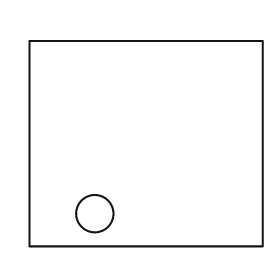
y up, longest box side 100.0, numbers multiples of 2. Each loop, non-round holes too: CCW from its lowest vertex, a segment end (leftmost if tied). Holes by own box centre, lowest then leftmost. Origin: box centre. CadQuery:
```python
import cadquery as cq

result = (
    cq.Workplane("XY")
    .moveTo(-50.0, -44.0)
    .lineTo(50.0, -44.0)
    .lineTo(50.0, 44.0)
    .lineTo(-50.0, 44.0)
    .close()
    .moveTo(-22.0, -30.0)
    .circle(8.0)
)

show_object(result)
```